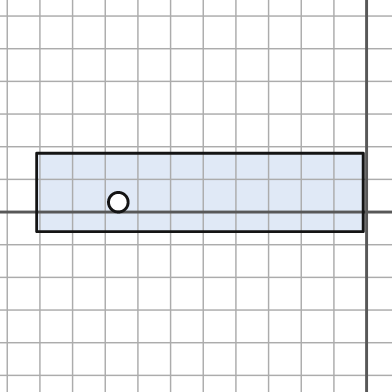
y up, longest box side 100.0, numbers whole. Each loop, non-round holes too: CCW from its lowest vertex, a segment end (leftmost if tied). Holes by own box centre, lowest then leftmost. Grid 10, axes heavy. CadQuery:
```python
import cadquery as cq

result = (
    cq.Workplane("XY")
    .moveTo(-101.0, -6.0)
    .lineTo(-1.0, -6.0)
    .lineTo(-1.0, 18.0)
    .lineTo(-101.0, 18.0)
    .close()
    .moveTo(-76.0, 3.0)
    .circle(3.0)
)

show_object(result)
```